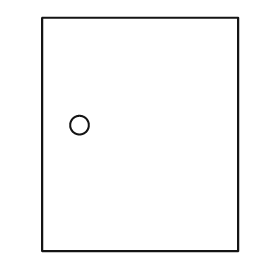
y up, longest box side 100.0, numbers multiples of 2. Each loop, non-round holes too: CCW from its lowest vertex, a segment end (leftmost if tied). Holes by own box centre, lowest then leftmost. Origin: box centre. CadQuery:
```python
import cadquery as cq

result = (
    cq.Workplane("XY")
    .moveTo(-42.0, -50.0)
    .lineTo(42.0, -50.0)
    .lineTo(42.0, 50.0)
    .lineTo(-42.0, 50.0)
    .close()
    .moveTo(-26.0, 4.0)
    .circle(4.0)
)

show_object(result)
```